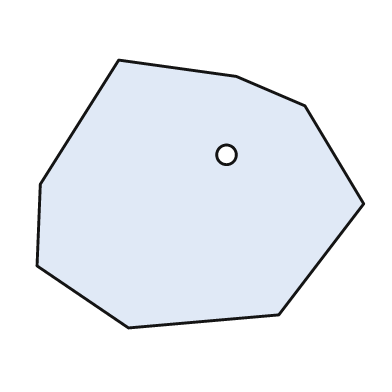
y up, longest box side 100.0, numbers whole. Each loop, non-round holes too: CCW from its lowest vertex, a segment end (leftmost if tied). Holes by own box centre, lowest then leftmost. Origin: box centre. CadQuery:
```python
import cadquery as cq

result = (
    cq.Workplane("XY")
    .moveTo(-22.0, -41.0)
    .lineTo(24.0, -37.0)
    .lineTo(50.0, -3.0)
    .lineTo(32.0, 27.0)
    .lineTo(11.0, 36.0)
    .lineTo(-25.0, 41.0)
    .lineTo(-49.0, 3.0)
    .lineTo(-50.0, -22.0)
    .close()
    .moveTo(8.0, 12.0)
    .circle(3.0)
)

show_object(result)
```